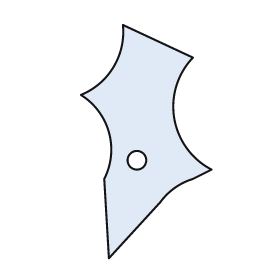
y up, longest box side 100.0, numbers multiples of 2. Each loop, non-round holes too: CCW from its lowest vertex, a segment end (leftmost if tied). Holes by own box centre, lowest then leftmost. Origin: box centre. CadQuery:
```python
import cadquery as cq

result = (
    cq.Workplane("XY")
    .moveTo(-16.0, -50.0)
    .lineTo(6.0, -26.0)
    .threePointArc((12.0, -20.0), (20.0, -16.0))
    .lineTo(28.0, -12.0)
    .threePointArc((12.0, 10.0), (20.0, 36.0))
    .lineTo(-10.0, 50.0)
    .threePointArc((-14.0, 32.0), (-28.0, 20.0))
    .threePointArc((-16.0, 4.0), (-18.0, -16.0))
    .close()
    .moveTo(-4.0, -8.0)
    .circle(4.0)
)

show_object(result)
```